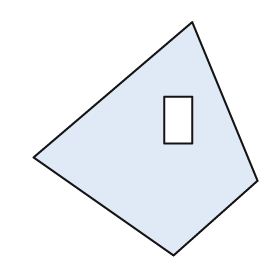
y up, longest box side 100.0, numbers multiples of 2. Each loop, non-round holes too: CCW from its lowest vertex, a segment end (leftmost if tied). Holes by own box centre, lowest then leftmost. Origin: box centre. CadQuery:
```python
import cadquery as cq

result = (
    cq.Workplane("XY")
    .moveTo(12.0, -50.0)
    .lineTo(48.0, -18.0)
    .lineTo(20.0, 50.0)
    .lineTo(-48.0, -8.0)
    .close()
    .moveTo(8.0, -2.0)
    .lineTo(20.0, -2.0)
    .lineTo(20.0, 18.0)
    .lineTo(8.0, 18.0)
    .close()
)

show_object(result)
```